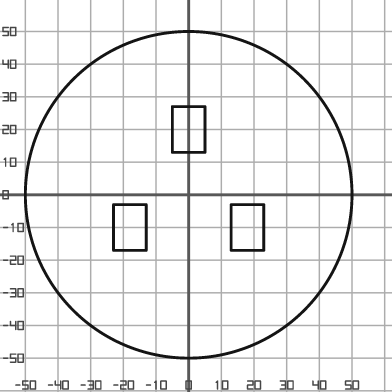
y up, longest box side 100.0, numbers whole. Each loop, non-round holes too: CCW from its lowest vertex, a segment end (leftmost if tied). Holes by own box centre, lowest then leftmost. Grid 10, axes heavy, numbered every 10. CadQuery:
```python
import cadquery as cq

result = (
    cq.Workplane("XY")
    .moveTo(0.0, 0.0)
    .circle(50.0)
    .moveTo(-23.0, -17.0)
    .lineTo(-13.0, -17.0)
    .lineTo(-13.0, -3.0)
    .lineTo(-23.0, -3.0)
    .close()
    .moveTo(13.0, -17.0)
    .lineTo(23.0, -17.0)
    .lineTo(23.0, -3.0)
    .lineTo(13.0, -3.0)
    .close()
    .moveTo(-5.0, 13.0)
    .lineTo(5.0, 13.0)
    .lineTo(5.0, 27.0)
    .lineTo(-5.0, 27.0)
    .close()
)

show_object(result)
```